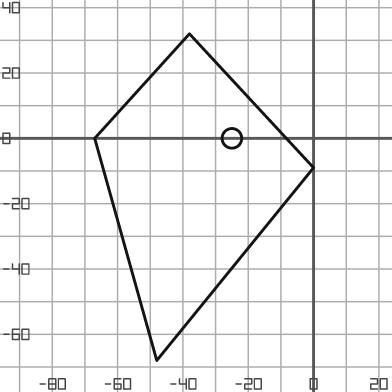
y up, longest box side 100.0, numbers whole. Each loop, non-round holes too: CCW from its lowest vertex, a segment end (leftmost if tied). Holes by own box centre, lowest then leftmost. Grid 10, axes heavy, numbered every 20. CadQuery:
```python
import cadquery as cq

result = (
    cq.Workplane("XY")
    .moveTo(-48.0, -68.0)
    .lineTo(0.0, -9.0)
    .lineTo(-38.0, 32.0)
    .lineTo(-67.0, 0.0)
    .close()
    .moveTo(-25.0, 0.0)
    .circle(3.0)
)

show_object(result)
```